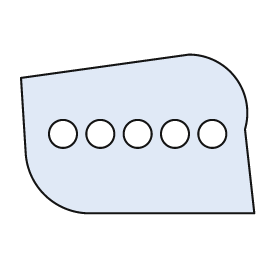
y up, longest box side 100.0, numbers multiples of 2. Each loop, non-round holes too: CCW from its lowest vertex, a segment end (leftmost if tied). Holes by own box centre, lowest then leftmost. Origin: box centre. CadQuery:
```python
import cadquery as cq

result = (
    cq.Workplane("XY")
    .moveTo(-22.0, -34.0)
    .lineTo(50.0, -34.0)
    .lineTo(46.0, 2.0)
    .threePointArc((42.0, 24.0), (22.0, 34.0))
    .lineTo(-50.0, 24.0)
    .lineTo(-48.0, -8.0)
    .threePointArc((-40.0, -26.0), (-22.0, -34.0))
    .close()
    .moveTo(-32.0, 0.0)
    .circle(6.0)
    .moveTo(-16.0, 0.0)
    .circle(6.0)
    .moveTo(0.0, 0.0)
    .circle(6.0)
    .moveTo(16.0, 0.0)
    .circle(6.0)
    .moveTo(32.0, 0.0)
    .circle(6.0)
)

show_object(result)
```